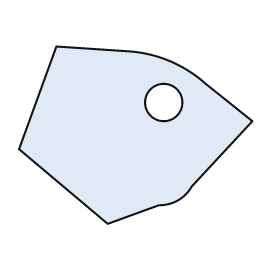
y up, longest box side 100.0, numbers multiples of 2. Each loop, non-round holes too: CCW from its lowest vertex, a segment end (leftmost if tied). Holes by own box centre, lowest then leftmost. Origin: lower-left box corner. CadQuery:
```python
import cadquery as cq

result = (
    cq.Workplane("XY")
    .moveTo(38.0, 0.0)
    .lineTo(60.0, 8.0)
    .threePointArc((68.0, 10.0), (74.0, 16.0))
    .lineTo(100.0, 44.0)
    .lineTo(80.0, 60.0)
    .threePointArc((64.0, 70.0), (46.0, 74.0))
    .lineTo(16.0, 76.0)
    .lineTo(0.0, 32.0)
    .close()
    .moveTo(62.0, 52.0)
    .circle(8.0)
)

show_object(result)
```